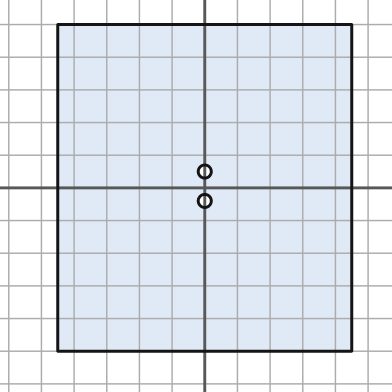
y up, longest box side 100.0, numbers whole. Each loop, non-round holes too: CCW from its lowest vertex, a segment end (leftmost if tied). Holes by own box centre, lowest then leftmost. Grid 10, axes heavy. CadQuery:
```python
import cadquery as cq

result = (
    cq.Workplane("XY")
    .moveTo(-45.0, -50.0)
    .lineTo(45.0, -50.0)
    .lineTo(45.0, 50.0)
    .lineTo(-45.0, 50.0)
    .close()
    .moveTo(0.0, -4.0)
    .circle(2.0)
    .moveTo(0.0, 5.0)
    .circle(2.0)
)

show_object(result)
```